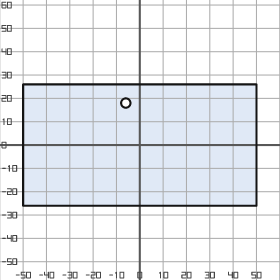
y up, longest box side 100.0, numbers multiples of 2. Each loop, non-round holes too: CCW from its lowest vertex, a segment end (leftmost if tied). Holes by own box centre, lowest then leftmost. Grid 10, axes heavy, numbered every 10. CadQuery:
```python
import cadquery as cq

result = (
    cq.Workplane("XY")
    .moveTo(-50.0, -26.0)
    .lineTo(50.0, -26.0)
    .lineTo(50.0, 26.0)
    .lineTo(-50.0, 26.0)
    .close()
    .moveTo(-6.0, 18.0)
    .circle(2.0)
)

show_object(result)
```